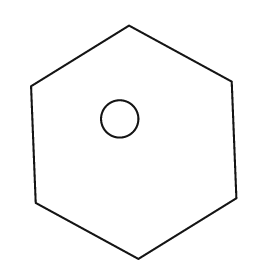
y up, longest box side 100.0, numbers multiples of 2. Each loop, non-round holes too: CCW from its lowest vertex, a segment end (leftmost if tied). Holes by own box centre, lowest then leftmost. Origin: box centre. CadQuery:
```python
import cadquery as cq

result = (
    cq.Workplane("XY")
    .moveTo(2.0, -50.0)
    .lineTo(44.0, -24.0)
    .lineTo(42.0, 26.0)
    .lineTo(-2.0, 50.0)
    .lineTo(-44.0, 24.0)
    .lineTo(-42.0, -26.0)
    .close()
    .moveTo(-6.0, 10.0)
    .circle(8.0)
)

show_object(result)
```